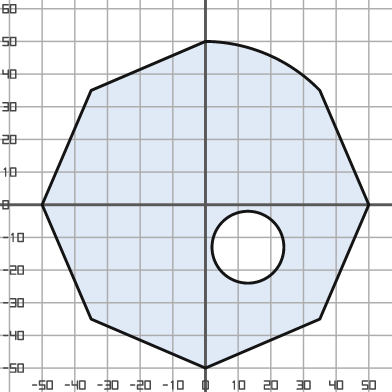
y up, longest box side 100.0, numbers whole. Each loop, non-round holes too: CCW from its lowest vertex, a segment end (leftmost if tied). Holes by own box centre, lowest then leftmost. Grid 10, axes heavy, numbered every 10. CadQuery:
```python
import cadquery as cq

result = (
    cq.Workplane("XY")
    .moveTo(0.0, -50.0)
    .lineTo(35.0, -35.0)
    .lineTo(50.0, 0.0)
    .lineTo(35.0, 35.0)
    .threePointArc((19.0, 46.0), (0.0, 50.0))
    .lineTo(-35.0, 35.0)
    .lineTo(-50.0, 0.0)
    .lineTo(-35.0, -35.0)
    .close()
    .moveTo(13.0, -13.0)
    .circle(11.0)
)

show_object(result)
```